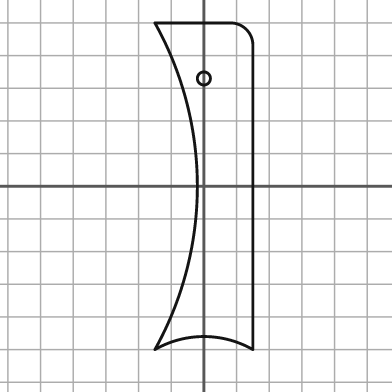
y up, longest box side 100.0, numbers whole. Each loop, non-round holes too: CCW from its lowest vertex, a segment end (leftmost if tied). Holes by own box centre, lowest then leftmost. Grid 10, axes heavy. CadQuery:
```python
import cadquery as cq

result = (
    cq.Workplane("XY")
    .moveTo(-15.0, -50.0)
    .threePointArc((0.0, -46.0), (15.0, -50.0))
    .lineTo(15.0, 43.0)
    .threePointArc((13.0, 48.0), (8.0, 50.0))
    .lineTo(-15.0, 50.0)
    .threePointArc((-2.0, 0.0), (-15.0, -50.0))
    .close()
    .moveTo(0.0, 33.0)
    .circle(2.0)
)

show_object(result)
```